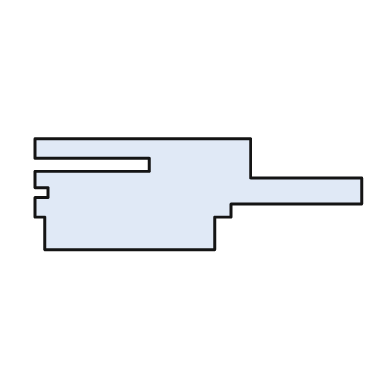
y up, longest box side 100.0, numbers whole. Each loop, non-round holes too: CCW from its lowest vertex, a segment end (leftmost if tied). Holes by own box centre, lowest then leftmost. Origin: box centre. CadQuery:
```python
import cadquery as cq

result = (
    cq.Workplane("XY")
    .moveTo(-47.0, -17.0)
    .lineTo(5.0, -17.0)
    .lineTo(5.0, -7.0)
    .lineTo(10.0, -7.0)
    .lineTo(10.0, -3.0)
    .lineTo(50.0, -3.0)
    .lineTo(50.0, 5.0)
    .lineTo(16.0, 5.0)
    .lineTo(16.0, 17.0)
    .lineTo(-50.0, 17.0)
    .lineTo(-50.0, 11.0)
    .lineTo(-15.0, 11.0)
    .lineTo(-15.0, 7.0)
    .lineTo(-50.0, 7.0)
    .lineTo(-50.0, 2.0)
    .lineTo(-46.0, 2.0)
    .lineTo(-46.0, -1.0)
    .lineTo(-50.0, -1.0)
    .lineTo(-50.0, -7.0)
    .lineTo(-47.0, -7.0)
    .close()
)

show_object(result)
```